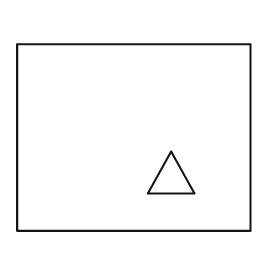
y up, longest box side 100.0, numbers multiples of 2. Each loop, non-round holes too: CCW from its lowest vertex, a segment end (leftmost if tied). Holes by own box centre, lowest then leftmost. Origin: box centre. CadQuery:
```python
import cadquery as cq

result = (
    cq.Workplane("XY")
    .moveTo(-50.0, -40.0)
    .lineTo(50.0, -40.0)
    .lineTo(50.0, 40.0)
    .lineTo(-50.0, 40.0)
    .close()
    .moveTo(6.0, -24.0)
    .lineTo(26.0, -24.0)
    .lineTo(16.0, -6.0)
    .close()
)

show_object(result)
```